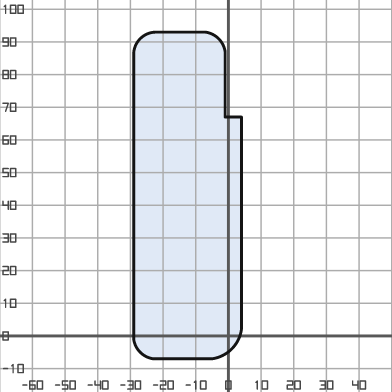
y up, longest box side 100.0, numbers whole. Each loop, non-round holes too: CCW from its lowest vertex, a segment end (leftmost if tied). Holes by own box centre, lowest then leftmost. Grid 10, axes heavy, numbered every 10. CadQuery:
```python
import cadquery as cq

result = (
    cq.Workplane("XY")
    .moveTo(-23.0, -7.0)
    .lineTo(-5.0, -7.0)
    .threePointArc((1.0, -4.0), (4.0, 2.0))
    .lineTo(4.0, 67.0)
    .lineTo(-1.0, 67.0)
    .lineTo(-1.0, 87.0)
    .threePointArc((-3.0, 91.0), (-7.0, 93.0))
    .lineTo(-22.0, 93.0)
    .threePointArc((-27.0, 91.0), (-29.0, 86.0))
    .lineTo(-29.0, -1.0)
    .threePointArc((-27.0, -5.0), (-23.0, -7.0))
    .close()
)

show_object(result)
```